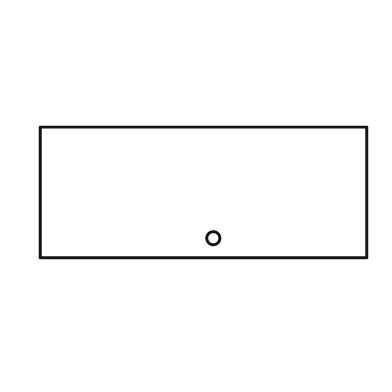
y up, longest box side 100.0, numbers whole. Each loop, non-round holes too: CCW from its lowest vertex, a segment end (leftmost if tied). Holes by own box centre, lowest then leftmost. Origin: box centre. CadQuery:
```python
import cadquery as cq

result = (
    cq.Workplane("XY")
    .moveTo(-50.0, -20.0)
    .lineTo(50.0, -20.0)
    .lineTo(50.0, 20.0)
    .lineTo(-50.0, 20.0)
    .close()
    .moveTo(3.0, -14.0)
    .circle(2.0)
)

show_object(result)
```